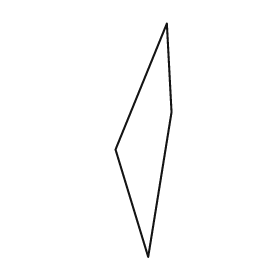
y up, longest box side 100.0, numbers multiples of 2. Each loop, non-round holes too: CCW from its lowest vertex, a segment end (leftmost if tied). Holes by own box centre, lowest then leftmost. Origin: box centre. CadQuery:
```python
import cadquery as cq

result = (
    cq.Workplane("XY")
    .moveTo(2.0, -50.0)
    .lineTo(12.0, 12.0)
    .lineTo(10.0, 50.0)
    .lineTo(-12.0, -4.0)
    .close()
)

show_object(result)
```